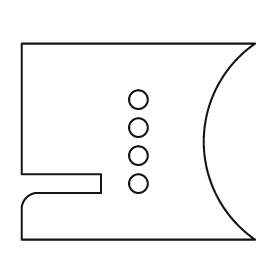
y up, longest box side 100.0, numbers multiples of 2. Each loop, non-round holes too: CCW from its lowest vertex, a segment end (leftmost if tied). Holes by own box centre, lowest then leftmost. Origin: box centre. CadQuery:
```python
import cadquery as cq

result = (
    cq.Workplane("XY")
    .moveTo(-50.0, -42.0)
    .lineTo(50.0, -42.0)
    .threePointArc((28.0, 0.0), (50.0, 42.0))
    .lineTo(-50.0, 42.0)
    .lineTo(-50.0, -14.0)
    .lineTo(-16.0, -14.0)
    .lineTo(-16.0, -22.0)
    .lineTo(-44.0, -22.0)
    .threePointArc((-48.0, -24.0), (-50.0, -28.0))
    .close()
    .moveTo(0.0, -18.0)
    .circle(4.0)
    .moveTo(0.0, -6.0)
    .circle(4.0)
    .moveTo(0.0, 6.0)
    .circle(4.0)
    .moveTo(0.0, 18.0)
    .circle(4.0)
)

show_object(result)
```